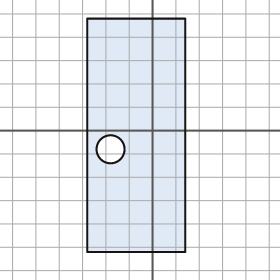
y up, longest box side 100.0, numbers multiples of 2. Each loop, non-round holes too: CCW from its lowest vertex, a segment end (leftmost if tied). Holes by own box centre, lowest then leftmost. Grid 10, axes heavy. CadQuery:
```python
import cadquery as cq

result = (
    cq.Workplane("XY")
    .moveTo(-28.0, -52.0)
    .lineTo(14.0, -52.0)
    .lineTo(14.0, 48.0)
    .lineTo(-28.0, 48.0)
    .close()
    .moveTo(-18.0, -8.0)
    .circle(6.0)
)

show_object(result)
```